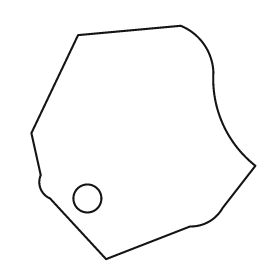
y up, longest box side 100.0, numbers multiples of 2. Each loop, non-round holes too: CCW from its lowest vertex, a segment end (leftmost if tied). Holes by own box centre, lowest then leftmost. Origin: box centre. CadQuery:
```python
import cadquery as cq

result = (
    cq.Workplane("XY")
    .moveTo(-16.0, -50.0)
    .lineTo(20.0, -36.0)
    .threePointArc((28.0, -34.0), (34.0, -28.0))
    .lineTo(48.0, -10.0)
    .threePointArc((34.0, 8.0), (30.0, 30.0))
    .threePointArc((26.0, 42.0), (16.0, 50.0))
    .lineTo(-28.0, 46.0)
    .lineTo(-48.0, 4.0)
    .lineTo(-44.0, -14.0)
    .threePointArc((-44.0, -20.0), (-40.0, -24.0))
    .close()
    .moveTo(-24.0, -24.0)
    .circle(6.0)
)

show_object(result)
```